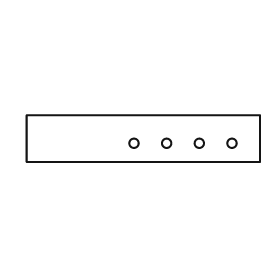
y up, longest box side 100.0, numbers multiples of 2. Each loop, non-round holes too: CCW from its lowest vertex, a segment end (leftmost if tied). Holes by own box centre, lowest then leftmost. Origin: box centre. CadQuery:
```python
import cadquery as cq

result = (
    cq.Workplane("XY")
    .moveTo(-50.0, -10.0)
    .lineTo(50.0, -10.0)
    .lineTo(50.0, 10.0)
    .lineTo(-50.0, 10.0)
    .close()
    .moveTo(-4.0, -2.0)
    .circle(2.0)
    .moveTo(10.0, -2.0)
    .circle(2.0)
    .moveTo(24.0, -2.0)
    .circle(2.0)
    .moveTo(38.0, -2.0)
    .circle(2.0)
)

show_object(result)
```